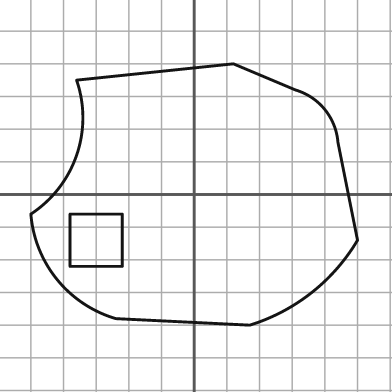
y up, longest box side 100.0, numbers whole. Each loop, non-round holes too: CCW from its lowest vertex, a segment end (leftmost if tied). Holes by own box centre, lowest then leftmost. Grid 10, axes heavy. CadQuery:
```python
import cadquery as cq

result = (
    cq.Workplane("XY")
    .moveTo(17.0, -40.0)
    .threePointArc((36.0, -30.0), (50.0, -14.0))
    .lineTo(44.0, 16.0)
    .threePointArc((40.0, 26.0), (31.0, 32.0))
    .lineTo(12.0, 40.0)
    .lineTo(-36.0, 35.0)
    .threePointArc((-36.0, 12.0), (-50.0, -6.0))
    .threePointArc((-42.0, -26.0), (-24.0, -38.0))
    .close()
    .moveTo(-38.0, -22.0)
    .lineTo(-22.0, -22.0)
    .lineTo(-22.0, -6.0)
    .lineTo(-38.0, -6.0)
    .close()
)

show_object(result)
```